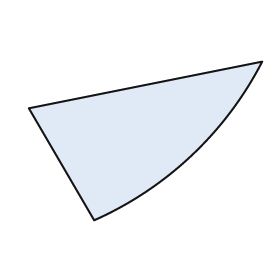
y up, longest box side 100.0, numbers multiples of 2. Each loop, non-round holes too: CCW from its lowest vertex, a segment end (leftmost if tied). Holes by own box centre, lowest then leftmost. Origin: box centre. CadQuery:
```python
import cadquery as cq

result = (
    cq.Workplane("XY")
    .moveTo(-22.0, -34.0)
    .threePointArc((20.0, -6.0), (50.0, 34.0))
    .lineTo(-50.0, 14.0)
    .close()
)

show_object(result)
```